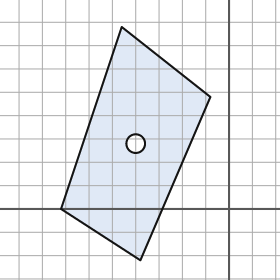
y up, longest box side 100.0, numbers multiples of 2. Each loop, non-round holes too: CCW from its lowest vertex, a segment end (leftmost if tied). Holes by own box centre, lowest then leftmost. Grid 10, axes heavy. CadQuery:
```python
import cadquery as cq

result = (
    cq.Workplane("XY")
    .moveTo(-38.0, -22.0)
    .lineTo(-8.0, 48.0)
    .lineTo(-46.0, 78.0)
    .lineTo(-72.0, 0.0)
    .close()
    .moveTo(-40.0, 28.0)
    .circle(4.0)
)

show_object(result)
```